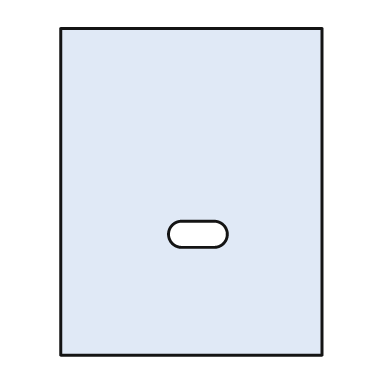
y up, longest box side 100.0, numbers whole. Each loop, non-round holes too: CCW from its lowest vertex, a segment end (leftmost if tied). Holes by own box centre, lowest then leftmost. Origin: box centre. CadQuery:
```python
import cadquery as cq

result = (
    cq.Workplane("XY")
    .moveTo(-40.0, -50.0)
    .lineTo(40.0, -50.0)
    .lineTo(40.0, 50.0)
    .lineTo(-40.0, 50.0)
    .close()
    .moveTo(-3.0, -17.0)
    .lineTo(7.0, -17.0)
    .threePointArc((11.0, -13.0), (7.0, -9.0))
    .lineTo(-3.0, -9.0)
    .threePointArc((-7.0, -13.0), (-3.0, -17.0))
    .close()
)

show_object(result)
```